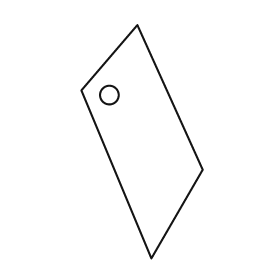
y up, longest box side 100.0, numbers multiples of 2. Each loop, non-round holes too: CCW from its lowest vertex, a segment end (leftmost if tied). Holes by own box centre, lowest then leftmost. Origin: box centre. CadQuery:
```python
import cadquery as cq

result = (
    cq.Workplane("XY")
    .moveTo(4.0, -50.0)
    .lineTo(26.0, -12.0)
    .lineTo(-2.0, 50.0)
    .lineTo(-26.0, 22.0)
    .close()
    .moveTo(-14.0, 20.0)
    .circle(4.0)
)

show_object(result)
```